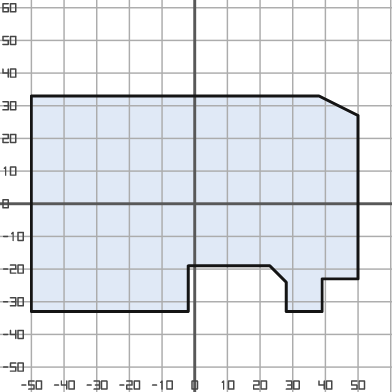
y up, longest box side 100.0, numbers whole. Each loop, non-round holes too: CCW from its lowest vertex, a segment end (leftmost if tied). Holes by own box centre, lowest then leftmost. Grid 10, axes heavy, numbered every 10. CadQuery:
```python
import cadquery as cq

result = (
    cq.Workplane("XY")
    .moveTo(-50.0, -33.0)
    .lineTo(-2.0, -33.0)
    .lineTo(-2.0, -19.0)
    .lineTo(23.0, -19.0)
    .lineTo(28.0, -24.0)
    .lineTo(28.0, -33.0)
    .lineTo(39.0, -33.0)
    .lineTo(39.0, -23.0)
    .lineTo(50.0, -23.0)
    .lineTo(50.0, 27.0)
    .lineTo(38.0, 33.0)
    .lineTo(-50.0, 33.0)
    .close()
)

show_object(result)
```